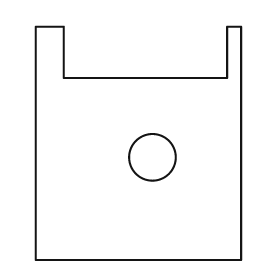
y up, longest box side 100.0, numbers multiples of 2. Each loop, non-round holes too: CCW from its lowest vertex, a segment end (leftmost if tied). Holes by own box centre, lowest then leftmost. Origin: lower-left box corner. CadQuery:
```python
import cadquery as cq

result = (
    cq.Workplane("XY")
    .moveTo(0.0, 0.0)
    .lineTo(88.0, 0.0)
    .lineTo(88.0, 100.0)
    .lineTo(82.0, 100.0)
    .lineTo(82.0, 78.0)
    .lineTo(12.0, 78.0)
    .lineTo(12.0, 100.0)
    .lineTo(0.0, 100.0)
    .close()
    .moveTo(50.0, 44.0)
    .circle(10.0)
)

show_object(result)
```